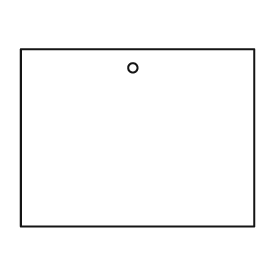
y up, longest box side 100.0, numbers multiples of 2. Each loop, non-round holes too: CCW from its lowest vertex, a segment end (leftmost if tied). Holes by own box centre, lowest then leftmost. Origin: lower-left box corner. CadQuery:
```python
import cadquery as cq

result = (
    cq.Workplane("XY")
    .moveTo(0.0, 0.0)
    .lineTo(100.0, 0.0)
    .lineTo(100.0, 76.0)
    .lineTo(0.0, 76.0)
    .close()
    .moveTo(48.0, 68.0)
    .circle(2.0)
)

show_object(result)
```